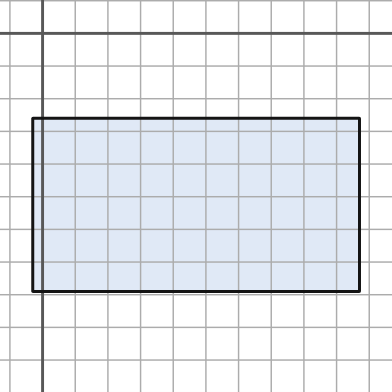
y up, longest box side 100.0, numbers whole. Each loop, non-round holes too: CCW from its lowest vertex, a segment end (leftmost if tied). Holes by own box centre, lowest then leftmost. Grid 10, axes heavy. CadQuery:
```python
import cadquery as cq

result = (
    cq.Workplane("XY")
    .moveTo(-3.0, -79.0)
    .lineTo(97.0, -79.0)
    .lineTo(97.0, -26.0)
    .lineTo(-3.0, -26.0)
    .close()
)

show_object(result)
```